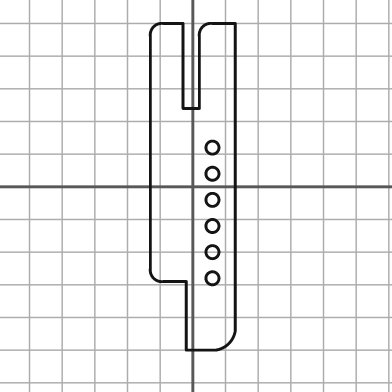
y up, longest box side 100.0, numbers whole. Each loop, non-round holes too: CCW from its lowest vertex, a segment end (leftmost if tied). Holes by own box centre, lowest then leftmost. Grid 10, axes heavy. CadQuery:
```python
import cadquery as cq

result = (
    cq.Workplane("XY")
    .moveTo(-2.0, -50.0)
    .lineTo(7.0, -50.0)
    .threePointArc((11.0, -48.0), (13.0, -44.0))
    .lineTo(13.0, 50.0)
    .lineTo(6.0, 50.0)
    .threePointArc((3.0, 49.0), (2.0, 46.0))
    .lineTo(2.0, 24.0)
    .lineTo(-3.0, 24.0)
    .lineTo(-3.0, 50.0)
    .lineTo(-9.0, 50.0)
    .threePointArc((-12.0, 49.0), (-13.0, 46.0))
    .lineTo(-13.0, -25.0)
    .threePointArc((-12.0, -28.0), (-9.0, -29.0))
    .lineTo(-2.0, -29.0)
    .close()
    .moveTo(6.0, -28.0)
    .circle(2.0)
    .moveTo(6.0, -20.0)
    .circle(2.0)
    .moveTo(6.0, -12.0)
    .circle(2.0)
    .moveTo(6.0, -4.0)
    .circle(2.0)
    .moveTo(6.0, 4.0)
    .circle(2.0)
    .moveTo(6.0, 12.0)
    .circle(2.0)
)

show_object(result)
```